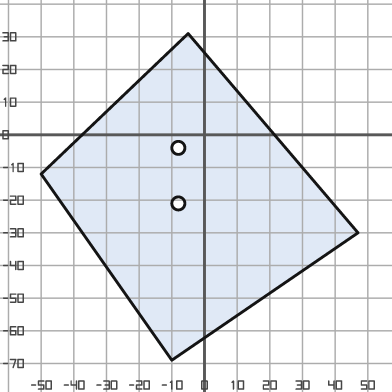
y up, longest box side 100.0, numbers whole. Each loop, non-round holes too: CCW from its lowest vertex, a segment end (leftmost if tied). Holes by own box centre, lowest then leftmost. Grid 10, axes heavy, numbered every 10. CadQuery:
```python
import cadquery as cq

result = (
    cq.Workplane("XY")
    .moveTo(-10.0, -69.0)
    .lineTo(47.0, -30.0)
    .lineTo(-5.0, 31.0)
    .lineTo(-50.0, -12.0)
    .close()
    .moveTo(-8.0, -21.0)
    .circle(2.0)
    .moveTo(-8.0, -4.0)
    .circle(2.0)
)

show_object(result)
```